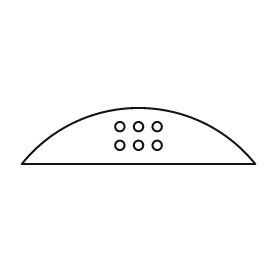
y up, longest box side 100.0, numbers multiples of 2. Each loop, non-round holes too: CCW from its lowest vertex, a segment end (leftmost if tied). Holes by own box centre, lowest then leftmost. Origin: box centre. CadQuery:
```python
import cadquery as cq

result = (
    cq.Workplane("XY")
    .moveTo(-50.0, -12.0)
    .lineTo(50.0, -12.0)
    .threePointArc((0.0, 12.0), (-50.0, -12.0))
    .close()
    .moveTo(-8.0, -4.0)
    .circle(2.0)
    .moveTo(0.0, -4.0)
    .circle(2.0)
    .moveTo(8.0, -4.0)
    .circle(2.0)
    .moveTo(-8.0, 4.0)
    .circle(2.0)
    .moveTo(0.0, 4.0)
    .circle(2.0)
    .moveTo(8.0, 4.0)
    .circle(2.0)
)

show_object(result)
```